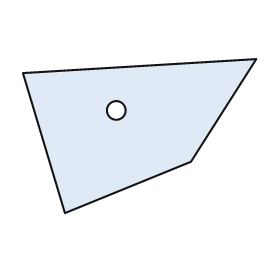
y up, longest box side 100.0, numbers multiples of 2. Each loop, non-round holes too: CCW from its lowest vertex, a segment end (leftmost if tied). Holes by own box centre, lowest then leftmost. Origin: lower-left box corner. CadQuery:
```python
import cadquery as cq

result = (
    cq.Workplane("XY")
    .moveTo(18.0, 0.0)
    .lineTo(72.0, 22.0)
    .lineTo(100.0, 66.0)
    .lineTo(0.0, 60.0)
    .close()
    .moveTo(40.0, 44.0)
    .circle(4.0)
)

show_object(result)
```